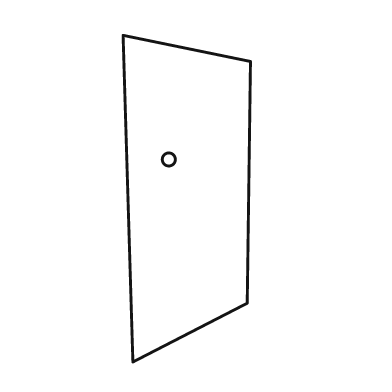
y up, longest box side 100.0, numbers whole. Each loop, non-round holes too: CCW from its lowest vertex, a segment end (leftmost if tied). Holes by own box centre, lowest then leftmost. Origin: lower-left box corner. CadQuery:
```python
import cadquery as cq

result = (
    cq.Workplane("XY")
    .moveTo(3.0, 0.0)
    .lineTo(38.0, 18.0)
    .lineTo(39.0, 92.0)
    .lineTo(0.0, 100.0)
    .close()
    .moveTo(14.0, 62.0)
    .circle(2.0)
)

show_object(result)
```